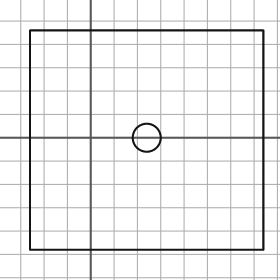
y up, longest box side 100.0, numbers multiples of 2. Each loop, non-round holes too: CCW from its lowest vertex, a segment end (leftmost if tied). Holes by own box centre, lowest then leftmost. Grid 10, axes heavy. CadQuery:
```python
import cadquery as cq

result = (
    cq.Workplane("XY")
    .moveTo(-26.0, -48.0)
    .lineTo(74.0, -48.0)
    .lineTo(74.0, 46.0)
    .lineTo(-26.0, 46.0)
    .close()
    .moveTo(24.0, 0.0)
    .circle(6.0)
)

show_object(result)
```